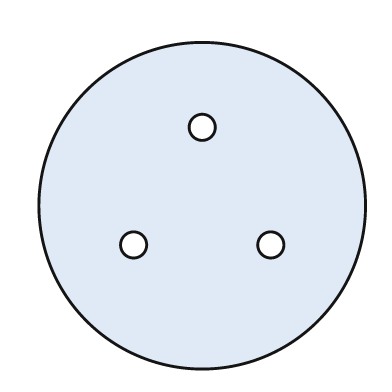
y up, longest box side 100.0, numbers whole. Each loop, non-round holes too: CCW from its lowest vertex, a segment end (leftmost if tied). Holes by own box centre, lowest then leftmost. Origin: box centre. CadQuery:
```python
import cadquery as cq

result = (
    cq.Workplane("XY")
    .moveTo(0.0, 0.0)
    .circle(50.0)
    .moveTo(-21.0, -12.0)
    .circle(4.0)
    .moveTo(21.0, -12.0)
    .circle(4.0)
    .moveTo(0.0, 24.0)
    .circle(4.0)
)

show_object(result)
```